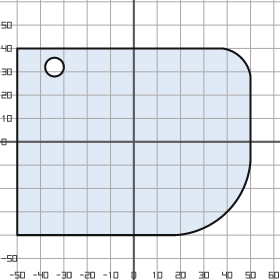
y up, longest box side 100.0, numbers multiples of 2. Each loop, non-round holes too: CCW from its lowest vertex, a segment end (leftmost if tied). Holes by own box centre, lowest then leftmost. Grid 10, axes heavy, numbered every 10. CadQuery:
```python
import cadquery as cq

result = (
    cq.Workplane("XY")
    .moveTo(-50.0, -40.0)
    .lineTo(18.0, -40.0)
    .threePointArc((40.0, -30.0), (50.0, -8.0))
    .lineTo(50.0, 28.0)
    .threePointArc((46.0, 36.0), (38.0, 40.0))
    .lineTo(-50.0, 40.0)
    .close()
    .moveTo(-34.0, 32.0)
    .circle(4.0)
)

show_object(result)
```